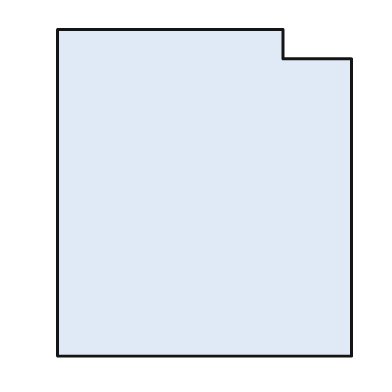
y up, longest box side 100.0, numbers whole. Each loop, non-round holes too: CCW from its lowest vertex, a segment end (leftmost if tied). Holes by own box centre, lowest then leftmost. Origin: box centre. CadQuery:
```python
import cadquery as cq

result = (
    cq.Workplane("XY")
    .moveTo(-45.0, -50.0)
    .lineTo(45.0, -50.0)
    .lineTo(45.0, 41.0)
    .lineTo(24.0, 41.0)
    .lineTo(24.0, 50.0)
    .lineTo(-45.0, 50.0)
    .close()
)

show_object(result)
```